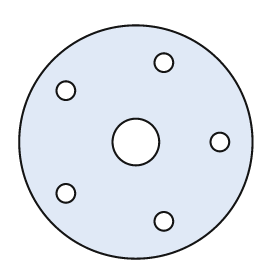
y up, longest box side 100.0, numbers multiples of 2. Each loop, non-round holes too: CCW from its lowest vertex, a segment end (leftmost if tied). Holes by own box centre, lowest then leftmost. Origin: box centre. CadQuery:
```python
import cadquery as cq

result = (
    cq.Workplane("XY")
    .moveTo(0.0, 0.0)
    .circle(50.0)
    .moveTo(12.0, -34.0)
    .circle(4.0)
    .moveTo(-30.0, -22.0)
    .circle(4.0)
    .moveTo(0.0, 0.0)
    .circle(10.0)
    .moveTo(36.0, 0.0)
    .circle(4.0)
    .moveTo(-30.0, 22.0)
    .circle(4.0)
    .moveTo(12.0, 34.0)
    .circle(4.0)
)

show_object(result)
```